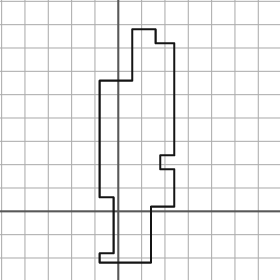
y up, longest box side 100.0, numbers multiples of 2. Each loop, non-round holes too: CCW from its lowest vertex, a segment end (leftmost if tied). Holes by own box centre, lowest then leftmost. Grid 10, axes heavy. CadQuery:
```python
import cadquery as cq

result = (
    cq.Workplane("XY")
    .moveTo(-8.0, -22.0)
    .lineTo(14.0, -22.0)
    .lineTo(14.0, 2.0)
    .lineTo(24.0, 2.0)
    .lineTo(24.0, 18.0)
    .lineTo(18.0, 18.0)
    .lineTo(18.0, 24.0)
    .lineTo(24.0, 24.0)
    .lineTo(24.0, 72.0)
    .lineTo(16.0, 72.0)
    .lineTo(16.0, 78.0)
    .lineTo(6.0, 78.0)
    .lineTo(6.0, 56.0)
    .lineTo(-8.0, 56.0)
    .lineTo(-8.0, 6.0)
    .lineTo(-2.0, 6.0)
    .lineTo(-2.0, -18.0)
    .lineTo(-8.0, -18.0)
    .close()
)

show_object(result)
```